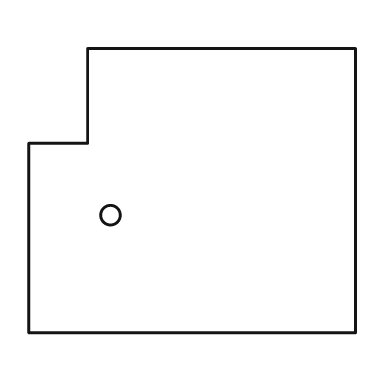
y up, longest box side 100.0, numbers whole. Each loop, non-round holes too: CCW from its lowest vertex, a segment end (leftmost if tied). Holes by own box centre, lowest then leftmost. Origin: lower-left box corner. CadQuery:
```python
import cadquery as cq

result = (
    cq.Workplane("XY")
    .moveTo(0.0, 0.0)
    .lineTo(100.0, 0.0)
    .lineTo(100.0, 87.0)
    .lineTo(18.0, 87.0)
    .lineTo(18.0, 58.0)
    .lineTo(0.0, 58.0)
    .close()
    .moveTo(25.0, 36.0)
    .circle(3.0)
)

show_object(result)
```